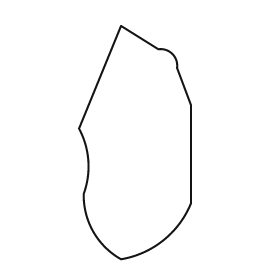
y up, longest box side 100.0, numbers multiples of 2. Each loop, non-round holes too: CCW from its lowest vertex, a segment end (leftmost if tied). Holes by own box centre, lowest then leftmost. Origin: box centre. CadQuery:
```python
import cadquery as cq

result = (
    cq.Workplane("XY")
    .moveTo(-6.0, -50.0)
    .threePointArc((12.0, -42.0), (24.0, -26.0))
    .lineTo(24.0, 16.0)
    .lineTo(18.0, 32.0)
    .threePointArc((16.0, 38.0), (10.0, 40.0))
    .lineTo(-6.0, 50.0)
    .lineTo(-24.0, 6.0)
    .threePointArc((-20.0, -8.0), (-22.0, -22.0))
    .threePointArc((-18.0, -38.0), (-6.0, -50.0))
    .close()
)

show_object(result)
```